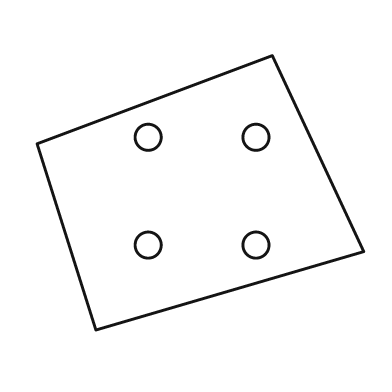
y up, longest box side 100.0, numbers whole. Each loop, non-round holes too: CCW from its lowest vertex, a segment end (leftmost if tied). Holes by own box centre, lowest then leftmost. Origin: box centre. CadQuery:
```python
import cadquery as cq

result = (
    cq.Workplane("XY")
    .moveTo(-32.0, -42.0)
    .lineTo(50.0, -18.0)
    .lineTo(22.0, 42.0)
    .lineTo(-50.0, 15.0)
    .close()
    .moveTo(-16.0, -16.0)
    .circle(4.0)
    .moveTo(17.0, -16.0)
    .circle(4.0)
    .moveTo(-16.0, 17.0)
    .circle(4.0)
    .moveTo(17.0, 17.0)
    .circle(4.0)
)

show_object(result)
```